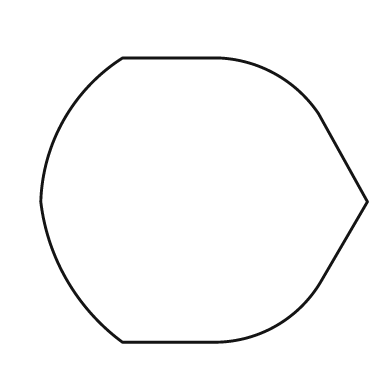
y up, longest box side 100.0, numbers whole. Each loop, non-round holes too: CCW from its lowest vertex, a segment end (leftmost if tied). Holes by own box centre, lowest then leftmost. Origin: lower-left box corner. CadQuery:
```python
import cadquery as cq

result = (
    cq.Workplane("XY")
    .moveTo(25.0, 0.0)
    .lineTo(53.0, 0.0)
    .threePointArc((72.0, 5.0), (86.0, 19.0))
    .lineTo(100.0, 43.0)
    .lineTo(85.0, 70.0)
    .threePointArc((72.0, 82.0), (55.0, 87.0))
    .lineTo(25.0, 87.0)
    .threePointArc((7.0, 68.0), (0.0, 43.0))
    .threePointArc((8.0, 19.0), (25.0, 0.0))
    .close()
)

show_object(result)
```